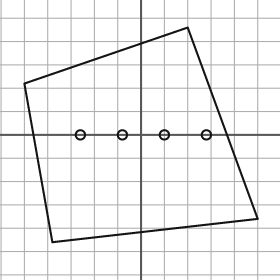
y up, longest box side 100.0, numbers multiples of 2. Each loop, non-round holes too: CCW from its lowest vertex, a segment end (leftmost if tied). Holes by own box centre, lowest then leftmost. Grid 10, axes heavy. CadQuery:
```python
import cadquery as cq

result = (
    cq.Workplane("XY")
    .moveTo(-38.0, -46.0)
    .lineTo(50.0, -36.0)
    .lineTo(20.0, 46.0)
    .lineTo(-50.0, 22.0)
    .close()
    .moveTo(-26.0, 0.0)
    .circle(2.0)
    .moveTo(-8.0, 0.0)
    .circle(2.0)
    .moveTo(10.0, 0.0)
    .circle(2.0)
    .moveTo(28.0, 0.0)
    .circle(2.0)
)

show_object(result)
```